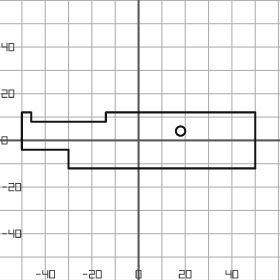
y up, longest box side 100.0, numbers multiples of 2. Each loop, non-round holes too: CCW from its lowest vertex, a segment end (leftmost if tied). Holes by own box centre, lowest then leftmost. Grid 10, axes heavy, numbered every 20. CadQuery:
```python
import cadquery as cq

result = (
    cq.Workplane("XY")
    .moveTo(-30.0, -12.0)
    .lineTo(50.0, -12.0)
    .lineTo(50.0, 12.0)
    .lineTo(-14.0, 12.0)
    .lineTo(-14.0, 8.0)
    .lineTo(-46.0, 8.0)
    .lineTo(-46.0, 12.0)
    .lineTo(-50.0, 12.0)
    .lineTo(-50.0, -4.0)
    .lineTo(-30.0, -4.0)
    .close()
    .moveTo(18.0, 4.0)
    .circle(2.0)
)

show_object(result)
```